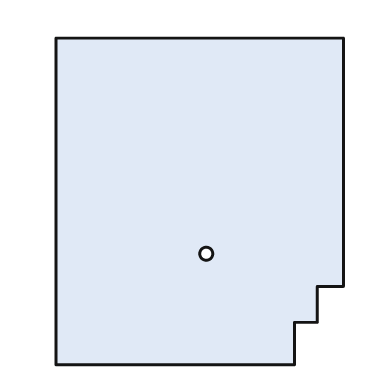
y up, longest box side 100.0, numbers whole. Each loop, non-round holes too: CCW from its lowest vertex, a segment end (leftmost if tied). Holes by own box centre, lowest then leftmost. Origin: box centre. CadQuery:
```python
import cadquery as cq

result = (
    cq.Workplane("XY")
    .moveTo(-44.0, -50.0)
    .lineTo(29.0, -50.0)
    .lineTo(29.0, -37.0)
    .lineTo(36.0, -37.0)
    .lineTo(36.0, -26.0)
    .lineTo(44.0, -26.0)
    .lineTo(44.0, 50.0)
    .lineTo(-44.0, 50.0)
    .close()
    .moveTo(2.0, -16.0)
    .circle(2.0)
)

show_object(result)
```